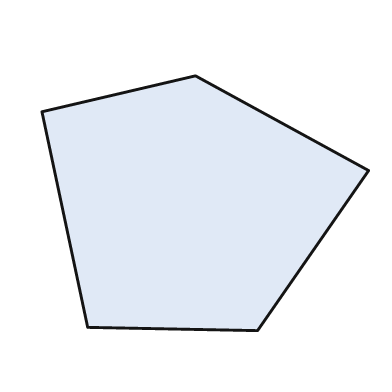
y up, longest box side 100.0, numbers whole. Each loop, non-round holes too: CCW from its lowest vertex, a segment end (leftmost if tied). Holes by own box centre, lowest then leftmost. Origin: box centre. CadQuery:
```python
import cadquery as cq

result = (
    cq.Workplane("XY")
    .moveTo(16.0, -39.0)
    .lineTo(50.0, 10.0)
    .lineTo(-3.0, 39.0)
    .lineTo(-50.0, 28.0)
    .lineTo(-36.0, -38.0)
    .close()
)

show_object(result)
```